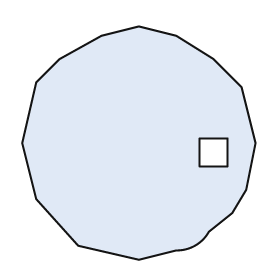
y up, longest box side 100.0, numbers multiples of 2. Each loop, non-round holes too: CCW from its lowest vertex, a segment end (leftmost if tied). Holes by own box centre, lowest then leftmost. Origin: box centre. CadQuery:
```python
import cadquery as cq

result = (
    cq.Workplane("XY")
    .moveTo(0.0, -50.0)
    .lineTo(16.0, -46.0)
    .threePointArc((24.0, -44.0), (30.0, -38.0))
    .lineTo(40.0, -30.0)
    .lineTo(46.0, -20.0)
    .lineTo(50.0, 0.0)
    .lineTo(44.0, 24.0)
    .lineTo(32.0, 36.0)
    .lineTo(16.0, 46.0)
    .lineTo(0.0, 50.0)
    .lineTo(-16.0, 46.0)
    .lineTo(-34.0, 36.0)
    .lineTo(-44.0, 26.0)
    .lineTo(-50.0, 0.0)
    .lineTo(-44.0, -24.0)
    .lineTo(-26.0, -44.0)
    .close()
    .moveTo(26.0, -10.0)
    .lineTo(38.0, -10.0)
    .lineTo(38.0, 2.0)
    .lineTo(26.0, 2.0)
    .close()
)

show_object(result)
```